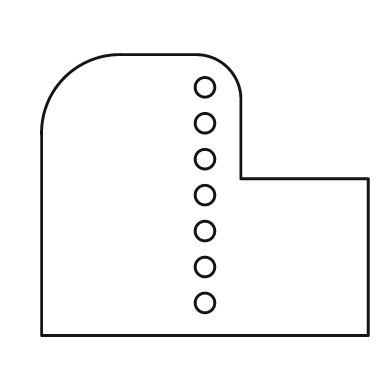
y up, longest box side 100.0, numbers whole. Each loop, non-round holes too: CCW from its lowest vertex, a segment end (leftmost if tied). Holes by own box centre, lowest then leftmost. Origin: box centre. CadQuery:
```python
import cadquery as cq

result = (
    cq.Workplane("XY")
    .moveTo(-50.0, -43.0)
    .lineTo(50.0, -43.0)
    .lineTo(50.0, 5.0)
    .lineTo(11.0, 5.0)
    .lineTo(11.0, 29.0)
    .threePointArc((7.0, 39.0), (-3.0, 43.0))
    .lineTo(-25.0, 43.0)
    .threePointArc((-43.0, 36.0), (-50.0, 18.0))
    .close()
    .moveTo(0.0, -33.0)
    .circle(3.0)
    .moveTo(0.0, -22.0)
    .circle(3.0)
    .moveTo(0.0, -11.0)
    .circle(3.0)
    .moveTo(0.0, 0.0)
    .circle(3.0)
    .moveTo(0.0, 11.0)
    .circle(3.0)
    .moveTo(0.0, 22.0)
    .circle(3.0)
    .moveTo(0.0, 33.0)
    .circle(3.0)
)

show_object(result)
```